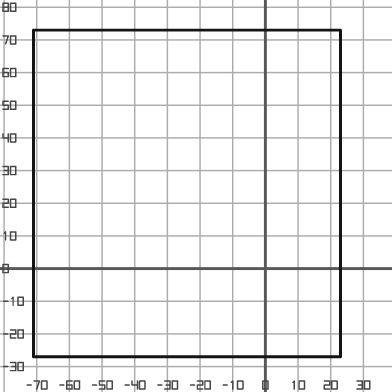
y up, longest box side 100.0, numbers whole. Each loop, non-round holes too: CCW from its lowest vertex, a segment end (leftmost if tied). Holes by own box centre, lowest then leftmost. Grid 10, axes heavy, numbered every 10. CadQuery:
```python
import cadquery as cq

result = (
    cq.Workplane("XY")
    .moveTo(-71.0, -27.0)
    .lineTo(23.0, -27.0)
    .lineTo(23.0, 73.0)
    .lineTo(-71.0, 73.0)
    .close()
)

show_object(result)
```